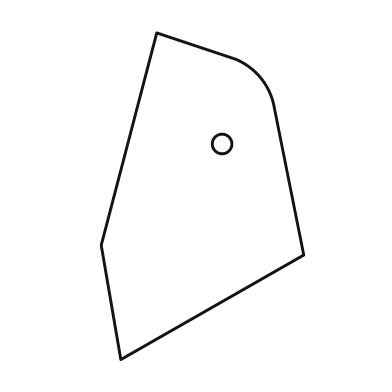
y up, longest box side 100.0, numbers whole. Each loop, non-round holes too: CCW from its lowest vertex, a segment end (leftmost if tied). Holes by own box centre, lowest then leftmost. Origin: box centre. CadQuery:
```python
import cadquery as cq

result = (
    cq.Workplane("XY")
    .moveTo(-25.0, -50.0)
    .lineTo(31.0, -18.0)
    .lineTo(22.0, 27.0)
    .threePointArc((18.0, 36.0), (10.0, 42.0))
    .lineTo(-14.0, 50.0)
    .lineTo(-31.0, -15.0)
    .close()
    .moveTo(6.0, 16.0)
    .circle(3.0)
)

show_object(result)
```